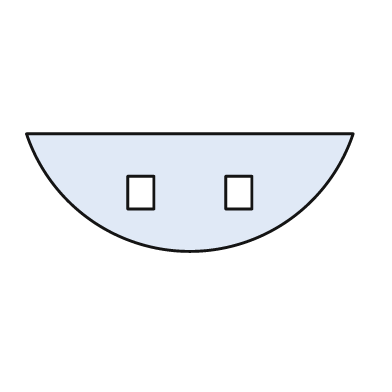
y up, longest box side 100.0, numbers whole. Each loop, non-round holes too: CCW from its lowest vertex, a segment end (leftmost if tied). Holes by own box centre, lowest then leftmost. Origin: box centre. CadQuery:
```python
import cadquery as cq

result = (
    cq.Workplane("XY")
    .moveTo(-50.0, 18.0)
    .threePointArc((0.0, -18.0), (50.0, 18.0))
    .close()
    .moveTo(-19.0, -5.0)
    .lineTo(-11.0, -5.0)
    .lineTo(-11.0, 5.0)
    .lineTo(-19.0, 5.0)
    .close()
    .moveTo(11.0, -5.0)
    .lineTo(19.0, -5.0)
    .lineTo(19.0, 5.0)
    .lineTo(11.0, 5.0)
    .close()
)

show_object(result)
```